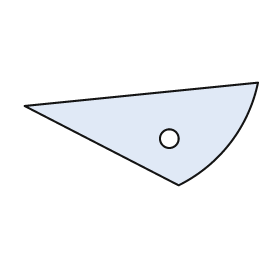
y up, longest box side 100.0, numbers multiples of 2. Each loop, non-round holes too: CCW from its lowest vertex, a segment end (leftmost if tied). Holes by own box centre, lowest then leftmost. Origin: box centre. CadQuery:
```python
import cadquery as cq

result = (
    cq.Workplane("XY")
    .moveTo(16.0, -22.0)
    .threePointArc((38.0, -4.0), (50.0, 22.0))
    .lineTo(-50.0, 12.0)
    .close()
    .moveTo(12.0, -2.0)
    .circle(4.0)
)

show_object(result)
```